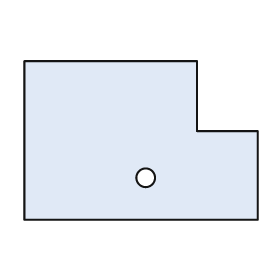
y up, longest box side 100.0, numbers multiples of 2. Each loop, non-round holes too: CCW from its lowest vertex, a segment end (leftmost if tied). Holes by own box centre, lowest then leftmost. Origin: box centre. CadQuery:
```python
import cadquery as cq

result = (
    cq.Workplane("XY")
    .moveTo(-50.0, -34.0)
    .lineTo(50.0, -34.0)
    .lineTo(50.0, 4.0)
    .lineTo(24.0, 4.0)
    .lineTo(24.0, 34.0)
    .lineTo(-50.0, 34.0)
    .close()
    .moveTo(2.0, -16.0)
    .circle(4.0)
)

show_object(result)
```